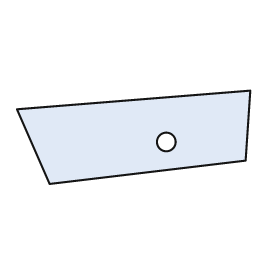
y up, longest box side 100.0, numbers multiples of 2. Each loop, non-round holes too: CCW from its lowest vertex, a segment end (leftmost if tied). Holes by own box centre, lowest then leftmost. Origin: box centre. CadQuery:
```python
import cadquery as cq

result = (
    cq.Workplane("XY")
    .moveTo(-36.0, -20.0)
    .lineTo(48.0, -10.0)
    .lineTo(50.0, 20.0)
    .lineTo(-50.0, 12.0)
    .close()
    .moveTo(14.0, -2.0)
    .circle(4.0)
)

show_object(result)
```